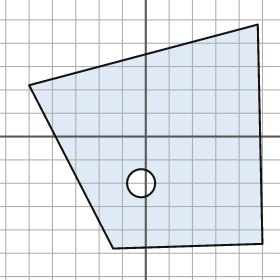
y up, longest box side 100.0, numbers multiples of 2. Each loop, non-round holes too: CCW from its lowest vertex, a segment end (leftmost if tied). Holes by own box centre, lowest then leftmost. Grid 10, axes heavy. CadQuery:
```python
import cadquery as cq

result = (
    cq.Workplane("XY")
    .moveTo(-14.0, -48.0)
    .lineTo(50.0, -46.0)
    .lineTo(48.0, 48.0)
    .lineTo(-50.0, 22.0)
    .close()
    .moveTo(-2.0, -20.0)
    .circle(6.0)
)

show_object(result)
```